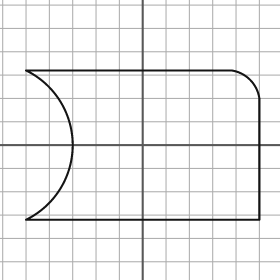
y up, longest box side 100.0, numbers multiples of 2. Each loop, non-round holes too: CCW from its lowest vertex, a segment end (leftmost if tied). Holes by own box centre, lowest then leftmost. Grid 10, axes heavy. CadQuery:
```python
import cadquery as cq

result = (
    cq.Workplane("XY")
    .moveTo(-50.0, -32.0)
    .lineTo(50.0, -32.0)
    .lineTo(50.0, 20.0)
    .threePointArc((46.0, 28.0), (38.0, 32.0))
    .lineTo(-50.0, 32.0)
    .threePointArc((-30.0, 0.0), (-50.0, -32.0))
    .close()
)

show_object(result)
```